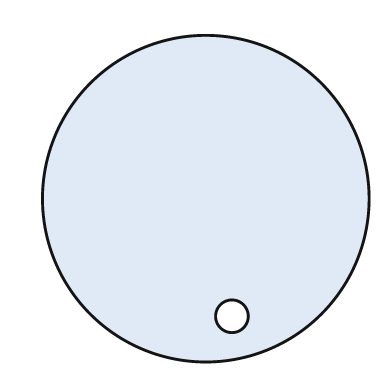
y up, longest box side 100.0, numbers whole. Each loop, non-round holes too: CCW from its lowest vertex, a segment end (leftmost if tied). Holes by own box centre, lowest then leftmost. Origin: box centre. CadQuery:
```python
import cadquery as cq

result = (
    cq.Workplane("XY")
    .moveTo(0.0, 0.0)
    .circle(50.0)
    .moveTo(8.0, -36.0)
    .circle(5.0)
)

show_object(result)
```